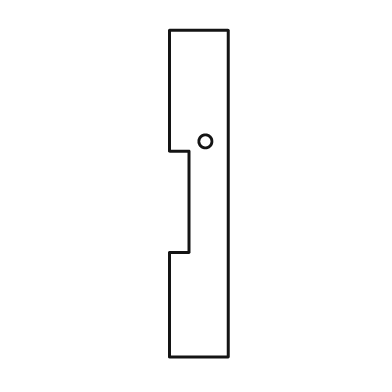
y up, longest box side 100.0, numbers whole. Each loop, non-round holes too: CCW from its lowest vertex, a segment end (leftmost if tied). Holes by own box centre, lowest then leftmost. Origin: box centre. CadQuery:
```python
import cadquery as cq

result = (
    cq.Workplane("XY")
    .moveTo(-9.0, -50.0)
    .lineTo(9.0, -50.0)
    .lineTo(9.0, 50.0)
    .lineTo(-9.0, 50.0)
    .lineTo(-9.0, 13.0)
    .lineTo(-3.0, 13.0)
    .lineTo(-3.0, -18.0)
    .lineTo(-9.0, -18.0)
    .close()
    .moveTo(2.0, 16.0)
    .circle(2.0)
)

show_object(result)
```